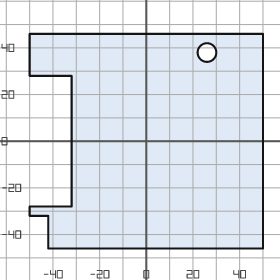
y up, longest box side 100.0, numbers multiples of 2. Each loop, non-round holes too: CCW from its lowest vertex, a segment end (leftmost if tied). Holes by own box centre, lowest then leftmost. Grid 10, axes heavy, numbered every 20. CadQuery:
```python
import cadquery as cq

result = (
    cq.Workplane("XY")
    .moveTo(-42.0, -46.0)
    .lineTo(50.0, -46.0)
    .lineTo(50.0, 46.0)
    .lineTo(-50.0, 46.0)
    .lineTo(-50.0, 28.0)
    .lineTo(-32.0, 28.0)
    .lineTo(-32.0, -28.0)
    .lineTo(-50.0, -28.0)
    .lineTo(-50.0, -32.0)
    .lineTo(-42.0, -32.0)
    .close()
    .moveTo(26.0, 38.0)
    .circle(4.0)
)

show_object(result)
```